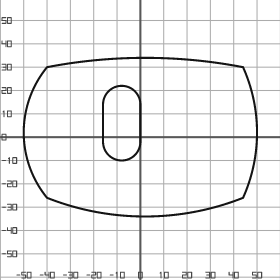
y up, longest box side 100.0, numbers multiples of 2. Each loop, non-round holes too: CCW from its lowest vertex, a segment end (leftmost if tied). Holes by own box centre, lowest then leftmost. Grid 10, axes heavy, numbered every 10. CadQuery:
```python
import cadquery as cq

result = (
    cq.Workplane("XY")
    .moveTo(-40.0, -26.0)
    .threePointArc((2.0, -34.0), (44.0, -26.0))
    .threePointArc((50.0, 2.0), (44.0, 30.0))
    .threePointArc((2.0, 34.0), (-40.0, 30.0))
    .threePointArc((-50.0, 2.0), (-40.0, -26.0))
    .close()
    .moveTo(-16.0, -2.0)
    .threePointArc((-8.0, -10.0), (0.0, -2.0))
    .lineTo(0.0, 14.0)
    .threePointArc((-8.0, 22.0), (-16.0, 14.0))
    .close()
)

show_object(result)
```